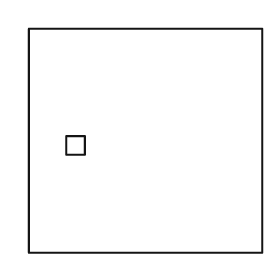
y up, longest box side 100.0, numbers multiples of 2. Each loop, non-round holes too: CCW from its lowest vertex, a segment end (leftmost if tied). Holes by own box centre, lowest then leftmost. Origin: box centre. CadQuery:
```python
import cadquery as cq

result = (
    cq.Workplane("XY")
    .moveTo(-50.0, -48.0)
    .lineTo(50.0, -48.0)
    .lineTo(50.0, 48.0)
    .lineTo(-50.0, 48.0)
    .close()
    .moveTo(-34.0, -6.0)
    .lineTo(-26.0, -6.0)
    .lineTo(-26.0, 2.0)
    .lineTo(-34.0, 2.0)
    .close()
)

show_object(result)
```